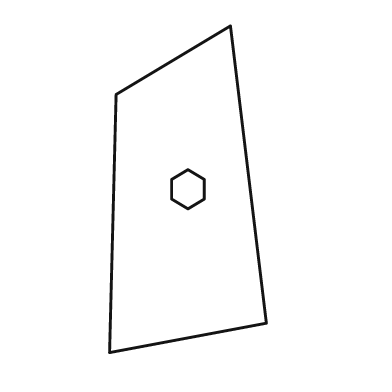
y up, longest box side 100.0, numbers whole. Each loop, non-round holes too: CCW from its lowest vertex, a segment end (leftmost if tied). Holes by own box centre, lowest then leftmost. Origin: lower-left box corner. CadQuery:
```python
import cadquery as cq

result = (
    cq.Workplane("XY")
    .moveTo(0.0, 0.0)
    .lineTo(48.0, 9.0)
    .lineTo(37.0, 100.0)
    .lineTo(2.0, 79.0)
    .close()
    .moveTo(24.0, 44.0)
    .lineTo(29.0, 47.0)
    .lineTo(29.0, 53.0)
    .lineTo(24.0, 56.0)
    .lineTo(19.0, 53.0)
    .lineTo(19.0, 47.0)
    .close()
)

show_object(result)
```